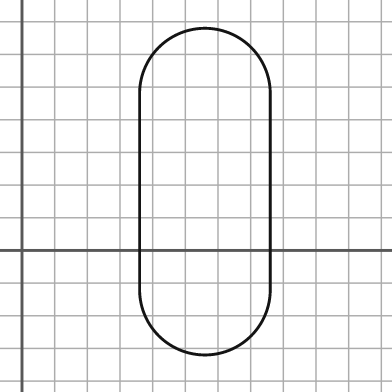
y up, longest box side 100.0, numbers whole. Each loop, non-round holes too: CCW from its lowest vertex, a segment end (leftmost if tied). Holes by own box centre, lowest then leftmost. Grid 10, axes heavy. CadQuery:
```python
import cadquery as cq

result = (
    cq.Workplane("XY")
    .moveTo(36.0, -12.0)
    .threePointArc((56.0, -32.0), (76.0, -12.0))
    .lineTo(76.0, 48.0)
    .threePointArc((56.0, 68.0), (36.0, 48.0))
    .close()
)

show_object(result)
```